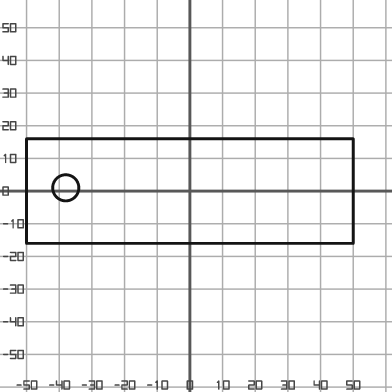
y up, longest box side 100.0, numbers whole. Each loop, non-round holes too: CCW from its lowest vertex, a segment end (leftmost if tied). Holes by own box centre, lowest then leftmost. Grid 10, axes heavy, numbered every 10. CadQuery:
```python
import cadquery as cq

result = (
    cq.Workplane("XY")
    .moveTo(-50.0, -16.0)
    .lineTo(50.0, -16.0)
    .lineTo(50.0, 16.0)
    .lineTo(-50.0, 16.0)
    .close()
    .moveTo(-38.0, 1.0)
    .circle(4.0)
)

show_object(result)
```